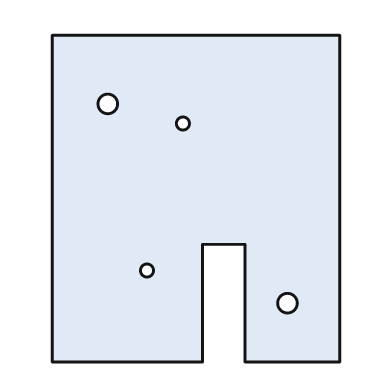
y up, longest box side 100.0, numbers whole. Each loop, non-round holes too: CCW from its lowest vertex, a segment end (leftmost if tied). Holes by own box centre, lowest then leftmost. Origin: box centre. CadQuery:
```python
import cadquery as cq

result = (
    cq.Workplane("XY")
    .moveTo(-44.0, -50.0)
    .lineTo(2.0, -50.0)
    .lineTo(2.0, -14.0)
    .lineTo(15.0, -14.0)
    .lineTo(15.0, -50.0)
    .lineTo(44.0, -50.0)
    .lineTo(44.0, 50.0)
    .lineTo(-44.0, 50.0)
    .close()
    .moveTo(28.0, -32.0)
    .circle(3.0)
    .moveTo(-15.0, -22.0)
    .circle(2.0)
    .moveTo(-4.0, 23.0)
    .circle(2.0)
    .moveTo(-27.0, 29.0)
    .circle(3.0)
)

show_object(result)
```